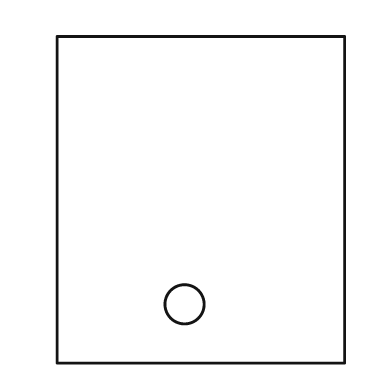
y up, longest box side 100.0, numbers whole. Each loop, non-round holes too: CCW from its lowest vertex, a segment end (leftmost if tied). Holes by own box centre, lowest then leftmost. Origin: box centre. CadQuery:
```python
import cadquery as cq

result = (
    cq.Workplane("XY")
    .moveTo(-44.0, -50.0)
    .lineTo(44.0, -50.0)
    .lineTo(44.0, 50.0)
    .lineTo(-44.0, 50.0)
    .close()
    .moveTo(-5.0, -32.0)
    .circle(6.0)
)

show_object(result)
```